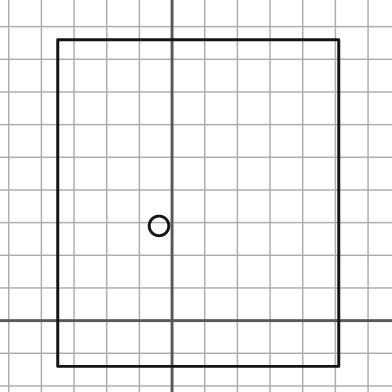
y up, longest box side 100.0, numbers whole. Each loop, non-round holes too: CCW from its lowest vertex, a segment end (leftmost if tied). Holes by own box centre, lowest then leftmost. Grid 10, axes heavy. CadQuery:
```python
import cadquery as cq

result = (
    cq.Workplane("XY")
    .moveTo(-35.0, -14.0)
    .lineTo(51.0, -14.0)
    .lineTo(51.0, 86.0)
    .lineTo(-35.0, 86.0)
    .close()
    .moveTo(-4.0, 29.0)
    .circle(3.0)
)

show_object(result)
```